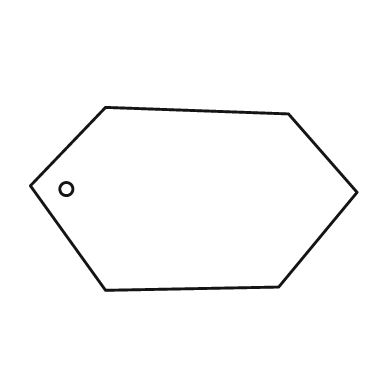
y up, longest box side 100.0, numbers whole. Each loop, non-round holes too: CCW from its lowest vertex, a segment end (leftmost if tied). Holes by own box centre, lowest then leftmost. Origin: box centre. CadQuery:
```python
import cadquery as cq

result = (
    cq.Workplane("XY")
    .moveTo(-27.0, -28.0)
    .lineTo(26.0, -27.0)
    .lineTo(50.0, 2.0)
    .lineTo(29.0, 26.0)
    .lineTo(-27.0, 28.0)
    .lineTo(-50.0, 4.0)
    .close()
    .moveTo(-39.0, 3.0)
    .circle(2.0)
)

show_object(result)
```